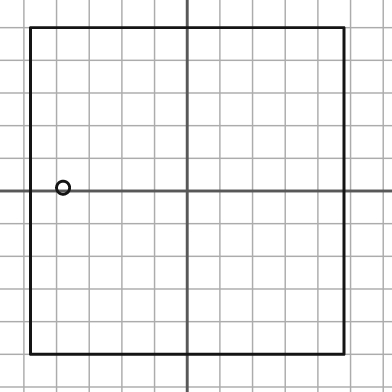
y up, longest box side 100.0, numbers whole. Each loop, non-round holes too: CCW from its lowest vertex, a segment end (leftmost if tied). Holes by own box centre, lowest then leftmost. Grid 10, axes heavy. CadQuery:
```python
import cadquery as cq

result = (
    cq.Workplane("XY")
    .moveTo(-48.0, -50.0)
    .lineTo(48.0, -50.0)
    .lineTo(48.0, 50.0)
    .lineTo(-48.0, 50.0)
    .close()
    .moveTo(-38.0, 1.0)
    .circle(2.0)
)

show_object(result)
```